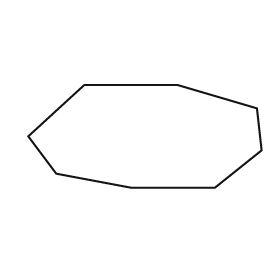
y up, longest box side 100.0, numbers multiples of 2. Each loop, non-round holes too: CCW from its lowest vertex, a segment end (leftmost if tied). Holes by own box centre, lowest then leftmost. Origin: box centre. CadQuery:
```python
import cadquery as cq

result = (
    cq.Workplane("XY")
    .moveTo(-6.0, -22.0)
    .lineTo(30.0, -22.0)
    .lineTo(50.0, -6.0)
    .lineTo(48.0, 12.0)
    .lineTo(14.0, 22.0)
    .lineTo(-26.0, 22.0)
    .lineTo(-50.0, 0.0)
    .lineTo(-38.0, -16.0)
    .close()
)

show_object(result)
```